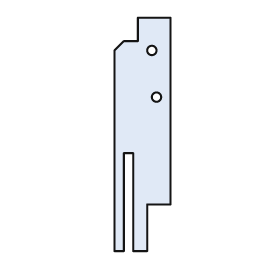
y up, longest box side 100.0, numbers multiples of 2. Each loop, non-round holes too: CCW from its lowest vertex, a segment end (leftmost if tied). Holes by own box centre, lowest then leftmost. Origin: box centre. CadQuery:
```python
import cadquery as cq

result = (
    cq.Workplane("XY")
    .moveTo(-12.0, -50.0)
    .lineTo(-8.0, -50.0)
    .lineTo(-8.0, -8.0)
    .lineTo(-4.0, -8.0)
    .lineTo(-4.0, -50.0)
    .lineTo(2.0, -50.0)
    .lineTo(2.0, -30.0)
    .lineTo(12.0, -30.0)
    .lineTo(12.0, 50.0)
    .lineTo(-2.0, 50.0)
    .lineTo(-2.0, 40.0)
    .lineTo(-8.0, 40.0)
    .lineTo(-12.0, 36.0)
    .close()
    .moveTo(6.0, 16.0)
    .circle(2.0)
    .moveTo(4.0, 36.0)
    .circle(2.0)
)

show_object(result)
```